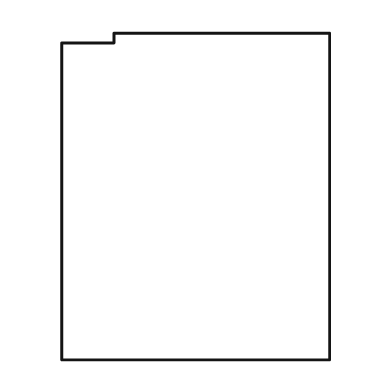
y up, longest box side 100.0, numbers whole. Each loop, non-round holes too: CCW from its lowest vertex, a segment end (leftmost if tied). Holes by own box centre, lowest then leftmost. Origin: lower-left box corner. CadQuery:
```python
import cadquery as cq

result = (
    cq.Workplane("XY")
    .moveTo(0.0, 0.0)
    .lineTo(82.0, 0.0)
    .lineTo(82.0, 100.0)
    .lineTo(16.0, 100.0)
    .lineTo(16.0, 97.0)
    .lineTo(0.0, 97.0)
    .close()
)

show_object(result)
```